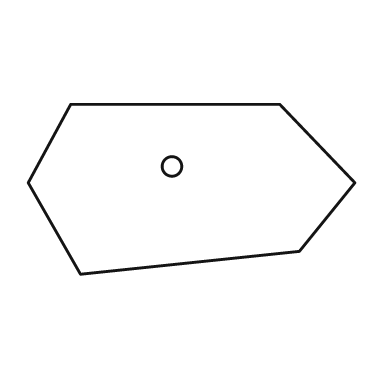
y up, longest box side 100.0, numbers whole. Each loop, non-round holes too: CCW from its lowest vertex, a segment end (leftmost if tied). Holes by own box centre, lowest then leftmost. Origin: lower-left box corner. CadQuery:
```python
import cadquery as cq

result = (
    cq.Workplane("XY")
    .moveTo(16.0, 0.0)
    .lineTo(83.0, 7.0)
    .lineTo(100.0, 28.0)
    .lineTo(77.0, 52.0)
    .lineTo(13.0, 52.0)
    .lineTo(0.0, 28.0)
    .close()
    .moveTo(44.0, 33.0)
    .circle(3.0)
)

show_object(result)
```